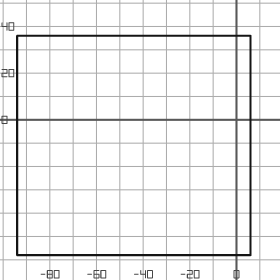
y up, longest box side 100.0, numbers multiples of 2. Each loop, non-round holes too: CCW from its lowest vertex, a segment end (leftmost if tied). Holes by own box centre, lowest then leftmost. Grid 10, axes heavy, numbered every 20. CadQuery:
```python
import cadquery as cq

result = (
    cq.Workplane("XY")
    .moveTo(-94.0, -58.0)
    .lineTo(6.0, -58.0)
    .lineTo(6.0, 36.0)
    .lineTo(-94.0, 36.0)
    .close()
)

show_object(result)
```